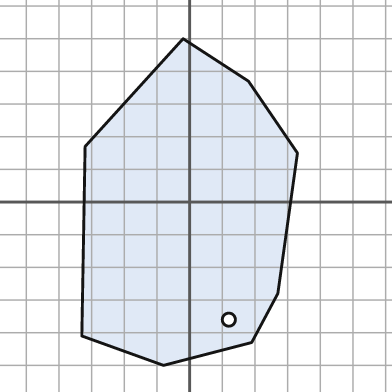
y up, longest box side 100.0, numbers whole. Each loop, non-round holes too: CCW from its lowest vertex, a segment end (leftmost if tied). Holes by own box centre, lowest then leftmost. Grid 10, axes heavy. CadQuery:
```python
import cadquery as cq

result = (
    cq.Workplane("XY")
    .moveTo(-8.0, -50.0)
    .lineTo(19.0, -43.0)
    .lineTo(27.0, -28.0)
    .lineTo(33.0, 15.0)
    .lineTo(18.0, 37.0)
    .lineTo(-2.0, 50.0)
    .lineTo(-32.0, 17.0)
    .lineTo(-33.0, -41.0)
    .close()
    .moveTo(12.0, -36.0)
    .circle(2.0)
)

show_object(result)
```